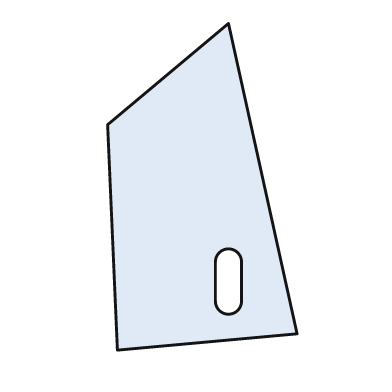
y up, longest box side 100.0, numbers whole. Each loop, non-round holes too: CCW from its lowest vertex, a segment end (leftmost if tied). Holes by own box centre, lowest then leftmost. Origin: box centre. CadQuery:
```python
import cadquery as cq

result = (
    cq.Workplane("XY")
    .moveTo(-26.0, -50.0)
    .lineTo(29.0, -45.0)
    .lineTo(8.0, 50.0)
    .lineTo(-29.0, 19.0)
    .close()
    .moveTo(4.0, -35.0)
    .threePointArc((8.0, -39.0), (12.0, -35.0))
    .lineTo(12.0, -23.0)
    .threePointArc((8.0, -19.0), (4.0, -23.0))
    .close()
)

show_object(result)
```